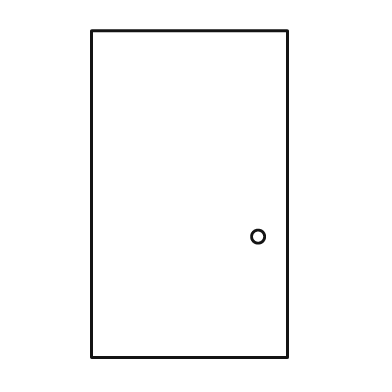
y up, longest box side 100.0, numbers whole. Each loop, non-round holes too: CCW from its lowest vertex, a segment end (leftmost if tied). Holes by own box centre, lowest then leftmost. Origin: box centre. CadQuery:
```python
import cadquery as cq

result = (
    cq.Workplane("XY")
    .moveTo(-30.0, -50.0)
    .lineTo(30.0, -50.0)
    .lineTo(30.0, 50.0)
    .lineTo(-30.0, 50.0)
    .close()
    .moveTo(21.0, -13.0)
    .circle(2.0)
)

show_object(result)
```